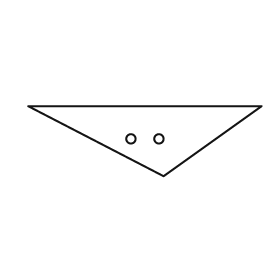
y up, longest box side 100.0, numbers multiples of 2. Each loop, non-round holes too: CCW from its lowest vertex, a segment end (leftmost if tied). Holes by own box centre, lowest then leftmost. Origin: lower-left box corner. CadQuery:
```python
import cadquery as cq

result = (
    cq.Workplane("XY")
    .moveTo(58.0, 0.0)
    .lineTo(100.0, 30.0)
    .lineTo(0.0, 30.0)
    .close()
    .moveTo(44.0, 16.0)
    .circle(2.0)
    .moveTo(56.0, 16.0)
    .circle(2.0)
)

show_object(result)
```